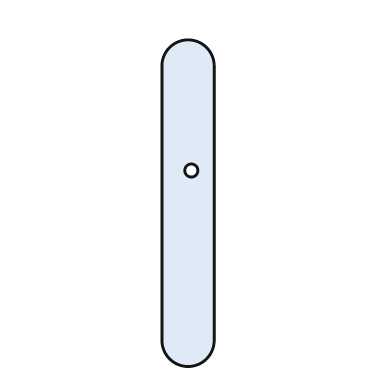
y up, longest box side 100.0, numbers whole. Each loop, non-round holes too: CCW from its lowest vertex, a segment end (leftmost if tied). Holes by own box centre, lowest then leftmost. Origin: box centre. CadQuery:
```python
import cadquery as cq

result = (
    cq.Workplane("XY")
    .moveTo(-8.0, -42.0)
    .threePointArc((0.0, -50.0), (8.0, -42.0))
    .lineTo(8.0, 42.0)
    .threePointArc((0.0, 50.0), (-8.0, 42.0))
    .close()
    .moveTo(1.0, 10.0)
    .circle(2.0)
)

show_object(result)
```